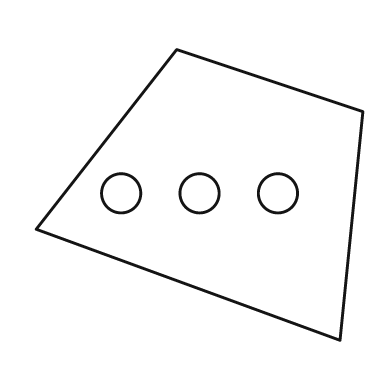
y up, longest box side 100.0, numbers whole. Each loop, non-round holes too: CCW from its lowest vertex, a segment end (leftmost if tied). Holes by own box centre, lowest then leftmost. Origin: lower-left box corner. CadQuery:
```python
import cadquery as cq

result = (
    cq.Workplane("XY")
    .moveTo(93.0, 0.0)
    .lineTo(100.0, 70.0)
    .lineTo(43.0, 89.0)
    .lineTo(0.0, 34.0)
    .close()
    .moveTo(26.0, 45.0)
    .circle(6.0)
    .moveTo(50.0, 45.0)
    .circle(6.0)
    .moveTo(74.0, 45.0)
    .circle(6.0)
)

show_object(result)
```